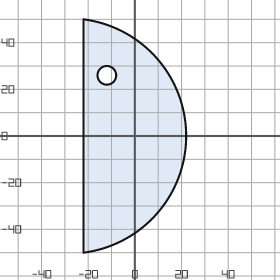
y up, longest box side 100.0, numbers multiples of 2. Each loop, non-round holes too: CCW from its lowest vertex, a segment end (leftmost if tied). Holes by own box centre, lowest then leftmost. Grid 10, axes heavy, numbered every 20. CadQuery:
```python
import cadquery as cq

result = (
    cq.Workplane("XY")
    .moveTo(-22.0, -50.0)
    .threePointArc((22.0, 0.0), (-22.0, 50.0))
    .close()
    .moveTo(-12.0, 26.0)
    .circle(4.0)
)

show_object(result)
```